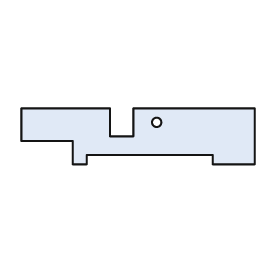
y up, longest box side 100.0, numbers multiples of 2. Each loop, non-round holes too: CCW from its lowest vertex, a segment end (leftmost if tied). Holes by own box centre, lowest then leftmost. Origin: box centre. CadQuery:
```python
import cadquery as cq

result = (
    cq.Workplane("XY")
    .moveTo(-28.0, -12.0)
    .lineTo(-22.0, -12.0)
    .lineTo(-22.0, -8.0)
    .lineTo(32.0, -8.0)
    .lineTo(32.0, -12.0)
    .lineTo(50.0, -12.0)
    .lineTo(50.0, 12.0)
    .lineTo(-2.0, 12.0)
    .lineTo(-2.0, 0.0)
    .lineTo(-12.0, 0.0)
    .lineTo(-12.0, 12.0)
    .lineTo(-50.0, 12.0)
    .lineTo(-50.0, -2.0)
    .lineTo(-28.0, -2.0)
    .close()
    .moveTo(8.0, 6.0)
    .circle(2.0)
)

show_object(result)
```